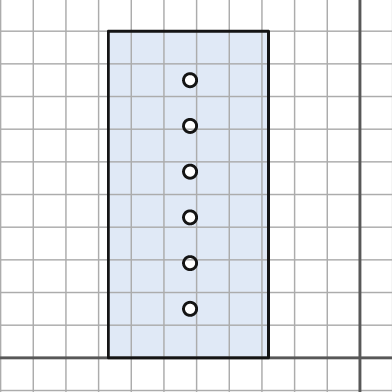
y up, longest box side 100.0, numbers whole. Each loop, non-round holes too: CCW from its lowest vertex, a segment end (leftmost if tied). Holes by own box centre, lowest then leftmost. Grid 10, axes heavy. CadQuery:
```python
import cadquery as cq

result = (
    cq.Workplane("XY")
    .moveTo(-77.0, 0.0)
    .lineTo(-28.0, 0.0)
    .lineTo(-28.0, 100.0)
    .lineTo(-77.0, 100.0)
    .close()
    .moveTo(-52.0, 15.0)
    .circle(2.0)
    .moveTo(-52.0, 29.0)
    .circle(2.0)
    .moveTo(-52.0, 43.0)
    .circle(2.0)
    .moveTo(-52.0, 57.0)
    .circle(2.0)
    .moveTo(-52.0, 71.0)
    .circle(2.0)
    .moveTo(-52.0, 85.0)
    .circle(2.0)
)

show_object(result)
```